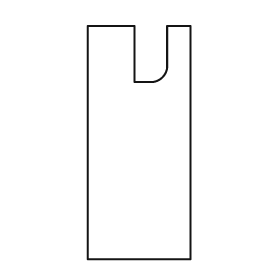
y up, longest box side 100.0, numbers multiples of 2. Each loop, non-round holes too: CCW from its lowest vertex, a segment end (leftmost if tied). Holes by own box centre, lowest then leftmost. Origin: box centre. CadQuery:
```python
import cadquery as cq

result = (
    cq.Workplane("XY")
    .moveTo(-22.0, -50.0)
    .lineTo(22.0, -50.0)
    .lineTo(22.0, 50.0)
    .lineTo(12.0, 50.0)
    .lineTo(12.0, 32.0)
    .threePointArc((10.0, 28.0), (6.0, 26.0))
    .lineTo(-2.0, 26.0)
    .lineTo(-2.0, 50.0)
    .lineTo(-22.0, 50.0)
    .close()
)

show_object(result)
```